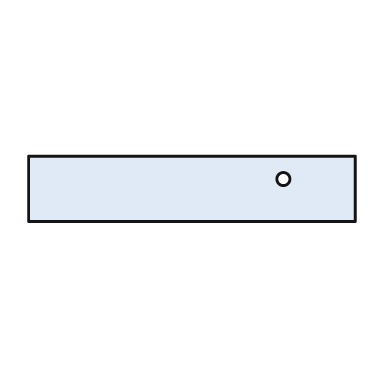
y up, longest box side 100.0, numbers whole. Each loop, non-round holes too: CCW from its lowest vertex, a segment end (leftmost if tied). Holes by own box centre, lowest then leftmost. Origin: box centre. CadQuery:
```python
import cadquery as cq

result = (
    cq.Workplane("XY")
    .moveTo(-50.0, -10.0)
    .lineTo(50.0, -10.0)
    .lineTo(50.0, 10.0)
    .lineTo(-50.0, 10.0)
    .close()
    .moveTo(28.0, 3.0)
    .circle(2.0)
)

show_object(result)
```